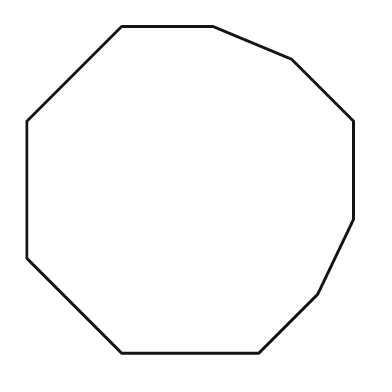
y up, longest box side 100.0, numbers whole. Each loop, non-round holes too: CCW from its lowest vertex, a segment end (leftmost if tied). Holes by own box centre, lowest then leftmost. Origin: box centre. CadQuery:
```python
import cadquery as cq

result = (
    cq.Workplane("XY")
    .moveTo(-21.0, -50.0)
    .lineTo(21.0, -50.0)
    .lineTo(39.0, -32.0)
    .lineTo(50.0, -9.0)
    .lineTo(50.0, 21.0)
    .lineTo(31.0, 40.0)
    .lineTo(7.0, 50.0)
    .lineTo(-21.0, 50.0)
    .lineTo(-50.0, 21.0)
    .lineTo(-50.0, -21.0)
    .close()
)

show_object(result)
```